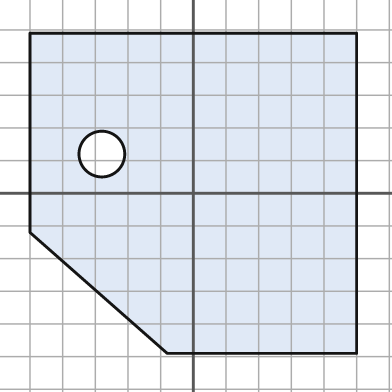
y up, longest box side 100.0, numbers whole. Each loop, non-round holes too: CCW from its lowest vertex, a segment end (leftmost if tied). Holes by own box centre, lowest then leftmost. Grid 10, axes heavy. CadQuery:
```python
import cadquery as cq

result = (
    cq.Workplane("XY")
    .moveTo(-8.0, -49.0)
    .lineTo(50.0, -49.0)
    .lineTo(50.0, 49.0)
    .lineTo(-50.0, 49.0)
    .lineTo(-50.0, -12.0)
    .close()
    .moveTo(-28.0, 12.0)
    .circle(7.0)
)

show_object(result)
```